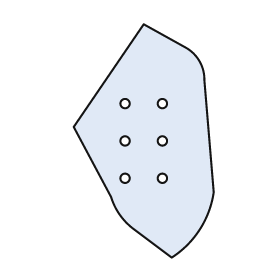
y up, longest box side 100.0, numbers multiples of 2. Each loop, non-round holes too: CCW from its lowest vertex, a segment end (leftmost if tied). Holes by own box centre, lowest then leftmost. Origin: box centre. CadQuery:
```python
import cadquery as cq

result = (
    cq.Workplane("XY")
    .moveTo(12.0, -50.0)
    .threePointArc((24.0, -38.0), (30.0, -22.0))
    .lineTo(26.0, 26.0)
    .threePointArc((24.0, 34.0), (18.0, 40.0))
    .lineTo(0.0, 50.0)
    .lineTo(-30.0, 6.0)
    .lineTo(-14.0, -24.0)
    .threePointArc((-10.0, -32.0), (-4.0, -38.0))
    .close()
    .moveTo(-8.0, -16.0)
    .circle(2.0)
    .moveTo(8.0, -16.0)
    .circle(2.0)
    .moveTo(-8.0, 0.0)
    .circle(2.0)
    .moveTo(8.0, 0.0)
    .circle(2.0)
    .moveTo(-8.0, 16.0)
    .circle(2.0)
    .moveTo(8.0, 16.0)
    .circle(2.0)
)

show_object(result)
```